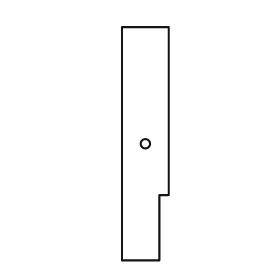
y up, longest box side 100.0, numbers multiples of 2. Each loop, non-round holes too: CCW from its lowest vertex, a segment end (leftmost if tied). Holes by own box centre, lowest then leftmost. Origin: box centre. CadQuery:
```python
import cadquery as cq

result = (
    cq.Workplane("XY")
    .moveTo(-10.0, -50.0)
    .lineTo(6.0, -50.0)
    .lineTo(6.0, -22.0)
    .lineTo(10.0, -22.0)
    .lineTo(10.0, 50.0)
    .lineTo(-10.0, 50.0)
    .close()
    .moveTo(0.0, 0.0)
    .circle(2.0)
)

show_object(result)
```